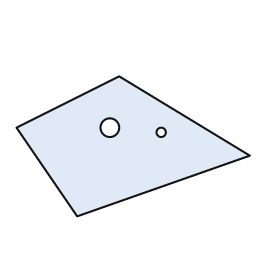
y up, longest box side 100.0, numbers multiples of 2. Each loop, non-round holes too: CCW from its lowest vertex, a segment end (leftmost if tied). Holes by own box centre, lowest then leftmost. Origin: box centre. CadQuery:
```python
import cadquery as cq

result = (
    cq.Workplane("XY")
    .moveTo(-24.0, -30.0)
    .lineTo(50.0, -4.0)
    .lineTo(-6.0, 30.0)
    .lineTo(-50.0, 8.0)
    .close()
    .moveTo(12.0, 6.0)
    .circle(2.0)
    .moveTo(-10.0, 8.0)
    .circle(4.0)
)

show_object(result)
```